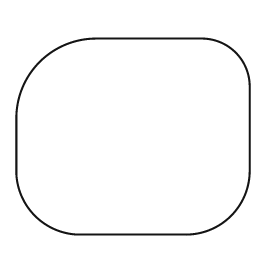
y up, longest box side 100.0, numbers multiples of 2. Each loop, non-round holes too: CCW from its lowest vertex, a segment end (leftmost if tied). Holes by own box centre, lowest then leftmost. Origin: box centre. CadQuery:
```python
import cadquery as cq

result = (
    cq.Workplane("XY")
    .moveTo(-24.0, -42.0)
    .lineTo(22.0, -42.0)
    .threePointArc((42.0, -34.0), (50.0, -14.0))
    .lineTo(50.0, 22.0)
    .threePointArc((44.0, 36.0), (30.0, 42.0))
    .lineTo(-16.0, 42.0)
    .threePointArc((-40.0, 32.0), (-50.0, 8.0))
    .lineTo(-50.0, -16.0)
    .threePointArc((-42.0, -34.0), (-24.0, -42.0))
    .close()
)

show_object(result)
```